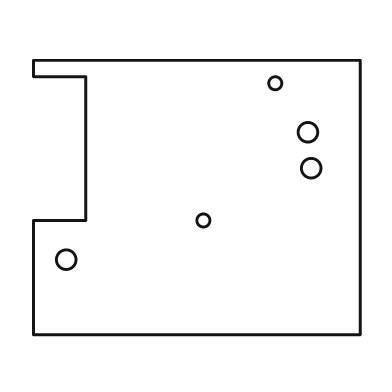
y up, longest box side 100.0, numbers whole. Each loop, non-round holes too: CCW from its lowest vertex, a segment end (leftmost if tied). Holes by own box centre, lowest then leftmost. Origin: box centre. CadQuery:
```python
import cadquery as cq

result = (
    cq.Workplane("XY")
    .moveTo(-50.0, -42.0)
    .lineTo(50.0, -42.0)
    .lineTo(50.0, 42.0)
    .lineTo(-50.0, 42.0)
    .lineTo(-50.0, 37.0)
    .lineTo(-34.0, 37.0)
    .lineTo(-34.0, -7.0)
    .lineTo(-50.0, -7.0)
    .close()
    .moveTo(-40.0, -19.0)
    .circle(3.0)
    .moveTo(2.0, -7.0)
    .circle(2.0)
    .moveTo(35.0, 9.0)
    .circle(3.0)
    .moveTo(34.0, 20.0)
    .circle(3.0)
    .moveTo(24.0, 35.0)
    .circle(2.0)
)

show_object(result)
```